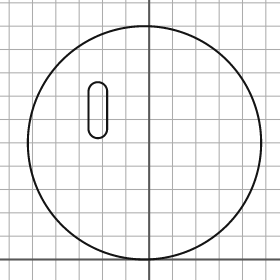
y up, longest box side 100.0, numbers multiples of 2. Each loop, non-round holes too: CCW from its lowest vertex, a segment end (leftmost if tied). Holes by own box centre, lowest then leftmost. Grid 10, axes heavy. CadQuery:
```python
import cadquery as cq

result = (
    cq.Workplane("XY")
    .moveTo(-2.0, 50.0)
    .circle(50.0)
    .moveTo(-26.0, 56.0)
    .threePointArc((-22.0, 52.0), (-18.0, 56.0))
    .lineTo(-18.0, 72.0)
    .threePointArc((-22.0, 76.0), (-26.0, 72.0))
    .close()
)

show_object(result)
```